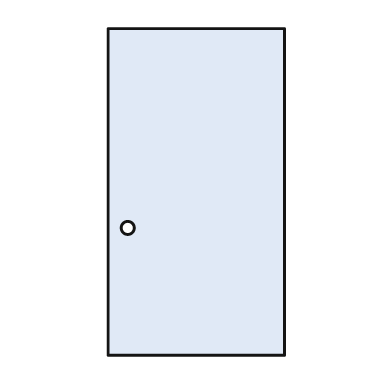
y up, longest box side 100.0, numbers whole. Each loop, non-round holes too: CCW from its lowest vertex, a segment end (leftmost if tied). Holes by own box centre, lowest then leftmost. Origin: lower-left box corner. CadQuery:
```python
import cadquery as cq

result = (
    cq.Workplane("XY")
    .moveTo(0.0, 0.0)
    .lineTo(54.0, 0.0)
    .lineTo(54.0, 100.0)
    .lineTo(0.0, 100.0)
    .close()
    .moveTo(6.0, 39.0)
    .circle(2.0)
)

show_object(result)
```